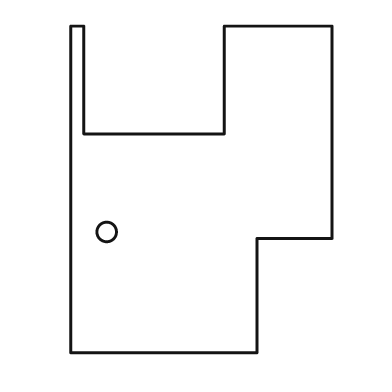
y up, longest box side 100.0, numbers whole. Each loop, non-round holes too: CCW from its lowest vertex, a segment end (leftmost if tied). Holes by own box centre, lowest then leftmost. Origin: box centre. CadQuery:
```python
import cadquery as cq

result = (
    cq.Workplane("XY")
    .moveTo(-40.0, -50.0)
    .lineTo(17.0, -50.0)
    .lineTo(17.0, -15.0)
    .lineTo(40.0, -15.0)
    .lineTo(40.0, 50.0)
    .lineTo(7.0, 50.0)
    .lineTo(7.0, 17.0)
    .lineTo(-36.0, 17.0)
    .lineTo(-36.0, 50.0)
    .lineTo(-40.0, 50.0)
    .close()
    .moveTo(-29.0, -13.0)
    .circle(3.0)
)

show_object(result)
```